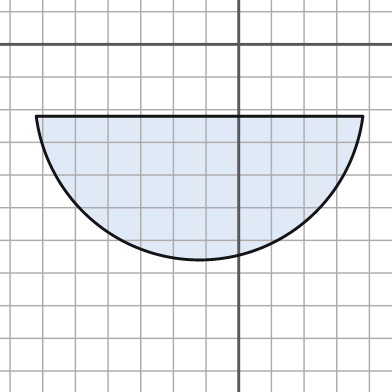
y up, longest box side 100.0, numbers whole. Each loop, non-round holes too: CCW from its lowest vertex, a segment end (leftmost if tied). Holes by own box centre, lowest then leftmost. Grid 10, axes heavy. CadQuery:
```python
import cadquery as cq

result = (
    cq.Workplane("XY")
    .moveTo(-62.0, -22.0)
    .threePointArc((-12.0, -66.0), (38.0, -22.0))
    .close()
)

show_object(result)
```